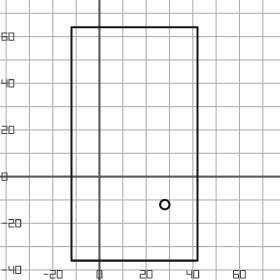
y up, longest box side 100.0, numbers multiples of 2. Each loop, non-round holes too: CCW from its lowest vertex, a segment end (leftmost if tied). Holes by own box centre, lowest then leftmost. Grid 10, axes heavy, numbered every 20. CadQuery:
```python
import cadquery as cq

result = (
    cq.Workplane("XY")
    .moveTo(-12.0, -36.0)
    .lineTo(42.0, -36.0)
    .lineTo(42.0, 64.0)
    .lineTo(-12.0, 64.0)
    .close()
    .moveTo(28.0, -12.0)
    .circle(2.0)
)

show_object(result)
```